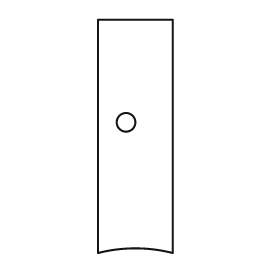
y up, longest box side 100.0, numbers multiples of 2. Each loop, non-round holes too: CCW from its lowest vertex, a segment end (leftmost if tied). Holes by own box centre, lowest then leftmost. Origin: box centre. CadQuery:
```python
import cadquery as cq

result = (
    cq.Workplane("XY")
    .moveTo(-16.0, -50.0)
    .threePointArc((0.0, -48.0), (16.0, -50.0))
    .lineTo(16.0, 50.0)
    .lineTo(-16.0, 50.0)
    .close()
    .moveTo(-4.0, 6.0)
    .circle(4.0)
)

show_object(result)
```